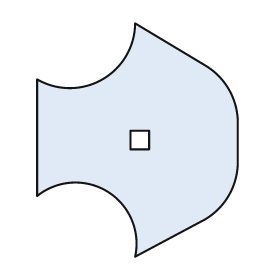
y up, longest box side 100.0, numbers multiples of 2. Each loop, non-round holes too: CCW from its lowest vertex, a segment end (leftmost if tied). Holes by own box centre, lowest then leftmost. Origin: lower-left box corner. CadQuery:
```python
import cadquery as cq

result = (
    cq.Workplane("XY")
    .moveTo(42.0, 0.0)
    .lineTo(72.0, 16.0)
    .threePointArc((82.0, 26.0), (86.0, 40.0))
    .lineTo(86.0, 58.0)
    .threePointArc((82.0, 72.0), (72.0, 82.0))
    .lineTo(42.0, 100.0)
    .threePointArc((28.0, 76.0), (0.0, 76.0))
    .lineTo(0.0, 26.0)
    .threePointArc((30.0, 28.0), (42.0, 0.0))
    .close()
    .moveTo(40.0, 46.0)
    .lineTo(48.0, 46.0)
    .lineTo(48.0, 54.0)
    .lineTo(40.0, 54.0)
    .close()
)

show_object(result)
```